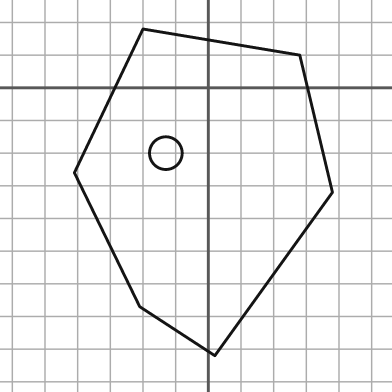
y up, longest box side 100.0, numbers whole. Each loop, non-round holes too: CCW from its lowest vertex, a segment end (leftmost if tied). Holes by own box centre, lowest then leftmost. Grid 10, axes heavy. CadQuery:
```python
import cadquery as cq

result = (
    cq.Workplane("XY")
    .moveTo(2.0, -82.0)
    .lineTo(38.0, -32.0)
    .lineTo(28.0, 10.0)
    .lineTo(-20.0, 18.0)
    .lineTo(-41.0, -26.0)
    .lineTo(-21.0, -67.0)
    .close()
    .moveTo(-13.0, -20.0)
    .circle(5.0)
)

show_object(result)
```